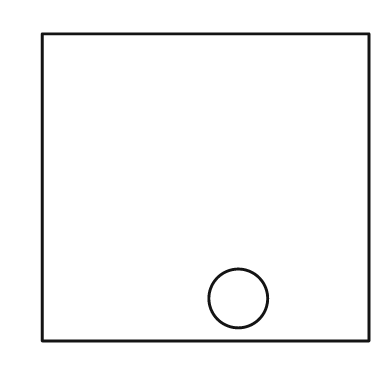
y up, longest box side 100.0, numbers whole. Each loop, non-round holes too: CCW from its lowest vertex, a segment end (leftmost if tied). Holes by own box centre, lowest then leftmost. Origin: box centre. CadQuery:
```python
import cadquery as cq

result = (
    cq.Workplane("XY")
    .moveTo(-50.0, -47.0)
    .lineTo(50.0, -47.0)
    .lineTo(50.0, 47.0)
    .lineTo(-50.0, 47.0)
    .close()
    .moveTo(10.0, -34.0)
    .circle(9.0)
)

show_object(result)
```